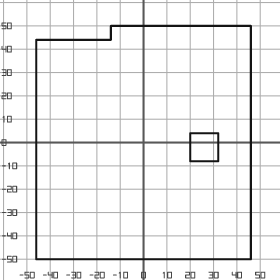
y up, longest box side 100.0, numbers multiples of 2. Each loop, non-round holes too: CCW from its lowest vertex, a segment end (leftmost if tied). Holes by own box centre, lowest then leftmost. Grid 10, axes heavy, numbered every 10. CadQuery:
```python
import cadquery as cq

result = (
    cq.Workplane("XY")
    .moveTo(-46.0, -50.0)
    .lineTo(46.0, -50.0)
    .lineTo(46.0, 50.0)
    .lineTo(-14.0, 50.0)
    .lineTo(-14.0, 44.0)
    .lineTo(-46.0, 44.0)
    .close()
    .moveTo(20.0, -8.0)
    .lineTo(32.0, -8.0)
    .lineTo(32.0, 4.0)
    .lineTo(20.0, 4.0)
    .close()
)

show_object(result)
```